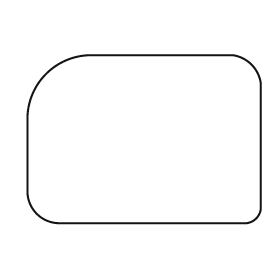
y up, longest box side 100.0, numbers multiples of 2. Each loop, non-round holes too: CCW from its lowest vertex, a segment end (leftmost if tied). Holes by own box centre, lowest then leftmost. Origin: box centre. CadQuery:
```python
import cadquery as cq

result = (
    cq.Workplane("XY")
    .moveTo(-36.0, -36.0)
    .lineTo(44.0, -36.0)
    .threePointArc((48.0, -34.0), (50.0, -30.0))
    .lineTo(50.0, 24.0)
    .threePointArc((46.0, 32.0), (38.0, 36.0))
    .lineTo(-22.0, 36.0)
    .threePointArc((-42.0, 28.0), (-50.0, 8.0))
    .lineTo(-50.0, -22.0)
    .threePointArc((-46.0, -32.0), (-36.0, -36.0))
    .close()
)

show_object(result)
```